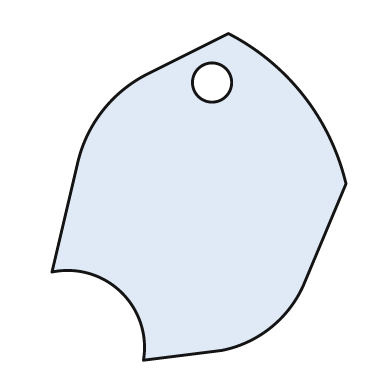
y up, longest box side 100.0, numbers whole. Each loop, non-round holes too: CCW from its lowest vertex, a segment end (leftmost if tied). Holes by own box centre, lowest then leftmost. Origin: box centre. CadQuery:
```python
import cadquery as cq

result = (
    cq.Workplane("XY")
    .moveTo(-17.0, -50.0)
    .lineTo(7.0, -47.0)
    .threePointArc((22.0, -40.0), (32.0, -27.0))
    .lineTo(45.0, 4.0)
    .threePointArc((32.0, 31.0), (9.0, 50.0))
    .lineTo(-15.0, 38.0)
    .threePointArc((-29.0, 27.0), (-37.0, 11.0))
    .lineTo(-45.0, -23.0)
    .threePointArc((-24.0, -29.0), (-17.0, -50.0))
    .close()
    .moveTo(4.0, 35.0)
    .circle(6.0)
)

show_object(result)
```